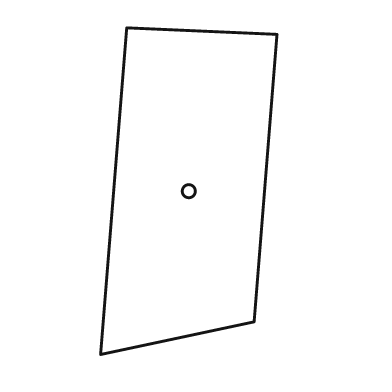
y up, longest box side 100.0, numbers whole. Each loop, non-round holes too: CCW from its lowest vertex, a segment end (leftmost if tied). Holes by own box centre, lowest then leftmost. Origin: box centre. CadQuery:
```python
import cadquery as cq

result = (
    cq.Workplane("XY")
    .moveTo(-27.0, -50.0)
    .lineTo(20.0, -40.0)
    .lineTo(27.0, 48.0)
    .lineTo(-19.0, 50.0)
    .close()
    .moveTo(0.0, 0.0)
    .circle(2.0)
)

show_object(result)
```